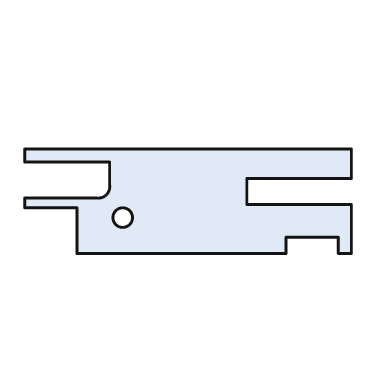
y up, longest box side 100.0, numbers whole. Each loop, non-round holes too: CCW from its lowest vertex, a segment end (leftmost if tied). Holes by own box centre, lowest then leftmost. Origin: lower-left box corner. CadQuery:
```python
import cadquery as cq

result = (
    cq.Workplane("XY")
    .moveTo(16.0, 0.0)
    .lineTo(80.0, 0.0)
    .lineTo(80.0, 5.0)
    .lineTo(96.0, 5.0)
    .lineTo(96.0, 0.0)
    .lineTo(100.0, 0.0)
    .lineTo(100.0, 15.0)
    .lineTo(68.0, 15.0)
    .lineTo(68.0, 23.0)
    .lineTo(100.0, 23.0)
    .lineTo(100.0, 32.0)
    .lineTo(0.0, 32.0)
    .lineTo(0.0, 28.0)
    .lineTo(26.0, 28.0)
    .lineTo(26.0, 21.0)
    .threePointArc((25.0, 18.0), (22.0, 17.0))
    .lineTo(0.0, 17.0)
    .lineTo(0.0, 14.0)
    .lineTo(16.0, 14.0)
    .close()
    .moveTo(30.0, 11.0)
    .circle(3.0)
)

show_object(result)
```